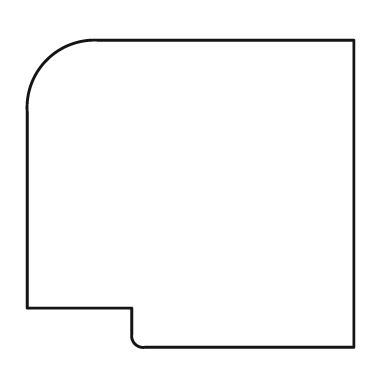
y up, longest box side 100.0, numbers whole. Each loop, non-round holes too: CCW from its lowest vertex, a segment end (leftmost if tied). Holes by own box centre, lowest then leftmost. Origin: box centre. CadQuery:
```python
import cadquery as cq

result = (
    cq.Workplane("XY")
    .moveTo(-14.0, -47.0)
    .lineTo(50.0, -47.0)
    .lineTo(50.0, 47.0)
    .lineTo(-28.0, 47.0)
    .threePointArc((-44.0, 41.0), (-50.0, 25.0))
    .lineTo(-50.0, -35.0)
    .lineTo(-18.0, -35.0)
    .lineTo(-18.0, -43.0)
    .threePointArc((-17.0, -46.0), (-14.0, -47.0))
    .close()
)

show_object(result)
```